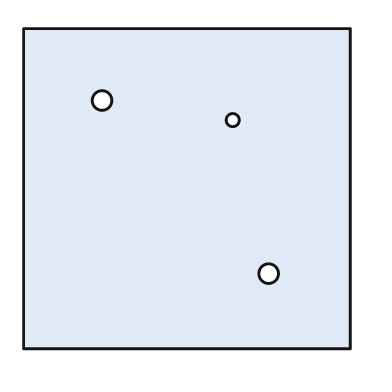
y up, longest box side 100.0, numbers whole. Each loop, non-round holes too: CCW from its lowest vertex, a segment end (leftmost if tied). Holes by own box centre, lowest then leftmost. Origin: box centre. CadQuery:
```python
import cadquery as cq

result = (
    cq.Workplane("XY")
    .moveTo(-50.0, -49.0)
    .lineTo(50.0, -49.0)
    .lineTo(50.0, 49.0)
    .lineTo(-50.0, 49.0)
    .close()
    .moveTo(25.0, -26.0)
    .circle(3.0)
    .moveTo(14.0, 21.0)
    .circle(2.0)
    .moveTo(-26.0, 27.0)
    .circle(3.0)
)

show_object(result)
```